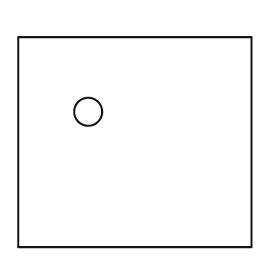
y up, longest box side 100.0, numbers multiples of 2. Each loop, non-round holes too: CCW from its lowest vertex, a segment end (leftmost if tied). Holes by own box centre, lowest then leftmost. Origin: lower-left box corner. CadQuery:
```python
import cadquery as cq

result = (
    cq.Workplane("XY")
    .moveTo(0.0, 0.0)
    .lineTo(100.0, 0.0)
    .lineTo(100.0, 90.0)
    .lineTo(0.0, 90.0)
    .close()
    .moveTo(30.0, 58.0)
    .circle(6.0)
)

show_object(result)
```